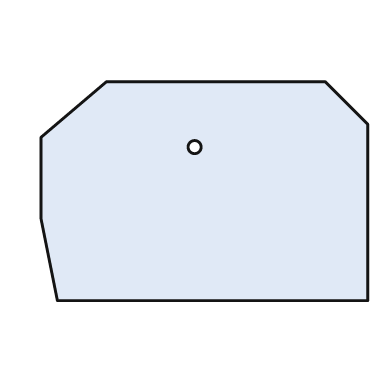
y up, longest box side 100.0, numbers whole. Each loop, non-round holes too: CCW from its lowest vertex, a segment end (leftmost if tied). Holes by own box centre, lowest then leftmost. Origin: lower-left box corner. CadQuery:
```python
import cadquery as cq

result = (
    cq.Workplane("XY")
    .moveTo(5.0, 0.0)
    .lineTo(100.0, 0.0)
    .lineTo(100.0, 54.0)
    .lineTo(87.0, 67.0)
    .lineTo(20.0, 67.0)
    .lineTo(0.0, 50.0)
    .lineTo(0.0, 25.0)
    .close()
    .moveTo(47.0, 47.0)
    .circle(2.0)
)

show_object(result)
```